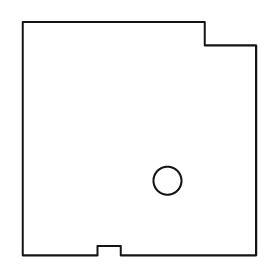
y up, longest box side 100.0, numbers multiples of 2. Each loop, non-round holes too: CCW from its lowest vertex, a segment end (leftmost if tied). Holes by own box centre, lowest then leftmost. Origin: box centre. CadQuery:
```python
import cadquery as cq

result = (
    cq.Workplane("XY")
    .moveTo(-50.0, -50.0)
    .lineTo(-18.0, -50.0)
    .lineTo(-18.0, -46.0)
    .lineTo(-8.0, -46.0)
    .lineTo(-8.0, -50.0)
    .lineTo(50.0, -50.0)
    .lineTo(50.0, 40.0)
    .lineTo(28.0, 40.0)
    .lineTo(28.0, 50.0)
    .lineTo(-50.0, 50.0)
    .close()
    .moveTo(12.0, -18.0)
    .circle(6.0)
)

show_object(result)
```